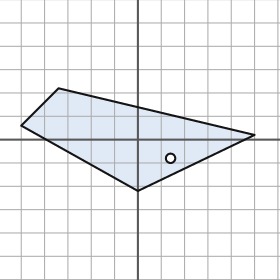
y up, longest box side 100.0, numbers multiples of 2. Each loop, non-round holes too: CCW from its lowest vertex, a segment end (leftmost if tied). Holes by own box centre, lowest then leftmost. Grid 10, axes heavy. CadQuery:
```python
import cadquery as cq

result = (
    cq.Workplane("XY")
    .moveTo(0.0, -22.0)
    .lineTo(50.0, 2.0)
    .lineTo(-34.0, 22.0)
    .lineTo(-50.0, 6.0)
    .close()
    .moveTo(14.0, -8.0)
    .circle(2.0)
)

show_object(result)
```